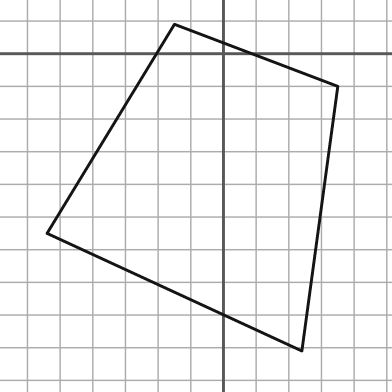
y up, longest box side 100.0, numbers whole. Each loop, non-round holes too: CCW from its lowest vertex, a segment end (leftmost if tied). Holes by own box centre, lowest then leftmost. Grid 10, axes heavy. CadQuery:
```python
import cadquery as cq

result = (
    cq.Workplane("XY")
    .moveTo(24.0, -91.0)
    .lineTo(35.0, -10.0)
    .lineTo(-15.0, 9.0)
    .lineTo(-54.0, -55.0)
    .close()
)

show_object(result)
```